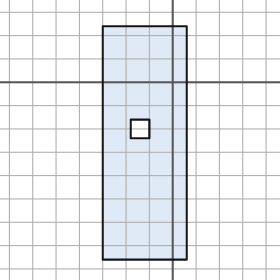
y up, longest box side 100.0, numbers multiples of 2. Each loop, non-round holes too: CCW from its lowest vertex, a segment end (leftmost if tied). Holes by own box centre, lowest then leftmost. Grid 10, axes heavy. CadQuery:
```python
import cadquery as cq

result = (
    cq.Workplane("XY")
    .moveTo(-30.0, -76.0)
    .lineTo(6.0, -76.0)
    .lineTo(6.0, 24.0)
    .lineTo(-30.0, 24.0)
    .close()
    .moveTo(-18.0, -24.0)
    .lineTo(-10.0, -24.0)
    .lineTo(-10.0, -16.0)
    .lineTo(-18.0, -16.0)
    .close()
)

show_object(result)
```